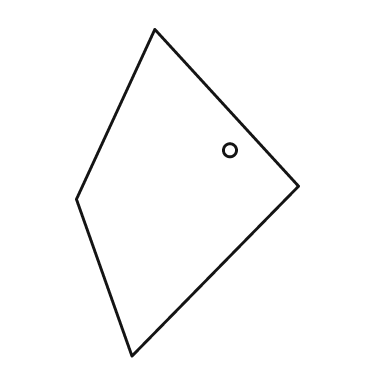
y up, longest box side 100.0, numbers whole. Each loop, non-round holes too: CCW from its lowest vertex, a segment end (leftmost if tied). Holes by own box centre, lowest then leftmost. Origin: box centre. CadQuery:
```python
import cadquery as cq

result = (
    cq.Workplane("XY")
    .moveTo(-17.0, -50.0)
    .lineTo(34.0, 2.0)
    .lineTo(-10.0, 50.0)
    .lineTo(-34.0, -2.0)
    .close()
    .moveTo(13.0, 13.0)
    .circle(2.0)
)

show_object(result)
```